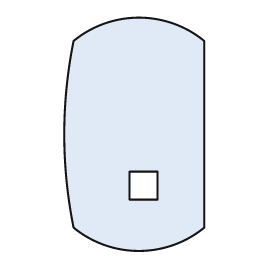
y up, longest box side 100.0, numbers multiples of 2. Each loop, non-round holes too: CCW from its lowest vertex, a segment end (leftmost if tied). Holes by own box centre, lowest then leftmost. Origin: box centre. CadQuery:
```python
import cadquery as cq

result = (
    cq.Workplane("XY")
    .moveTo(-26.0, -40.0)
    .threePointArc((2.0, -50.0), (30.0, -40.0))
    .lineTo(30.0, 40.0)
    .threePointArc((2.0, 50.0), (-26.0, 40.0))
    .threePointArc((-30.0, 0.0), (-26.0, -40.0))
    .close()
    .moveTo(-2.0, -28.0)
    .lineTo(10.0, -28.0)
    .lineTo(10.0, -16.0)
    .lineTo(-2.0, -16.0)
    .close()
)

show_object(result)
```